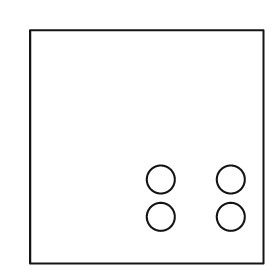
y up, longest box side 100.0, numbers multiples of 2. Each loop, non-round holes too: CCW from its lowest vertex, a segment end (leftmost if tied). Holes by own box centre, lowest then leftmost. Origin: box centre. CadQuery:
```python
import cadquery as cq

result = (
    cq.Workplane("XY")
    .moveTo(-50.0, -50.0)
    .lineTo(50.0, -50.0)
    .lineTo(50.0, 50.0)
    .lineTo(-50.0, 50.0)
    .close()
    .moveTo(6.0, -30.0)
    .circle(6.0)
    .moveTo(36.0, -30.0)
    .circle(6.0)
    .moveTo(6.0, -14.0)
    .circle(6.0)
    .moveTo(36.0, -14.0)
    .circle(6.0)
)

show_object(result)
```